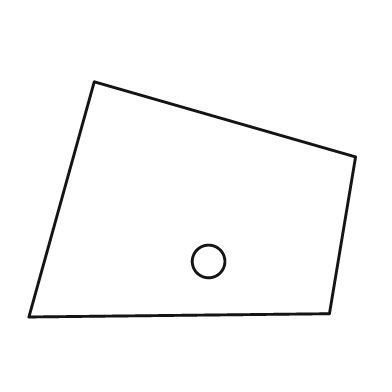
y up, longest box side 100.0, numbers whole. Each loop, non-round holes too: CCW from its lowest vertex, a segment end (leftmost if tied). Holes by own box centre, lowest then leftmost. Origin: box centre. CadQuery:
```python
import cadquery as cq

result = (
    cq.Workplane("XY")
    .moveTo(-50.0, -36.0)
    .lineTo(42.0, -35.0)
    .lineTo(50.0, 13.0)
    .lineTo(-30.0, 36.0)
    .close()
    .moveTo(5.0, -19.0)
    .circle(5.0)
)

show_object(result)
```